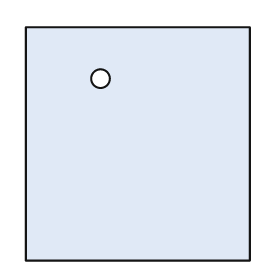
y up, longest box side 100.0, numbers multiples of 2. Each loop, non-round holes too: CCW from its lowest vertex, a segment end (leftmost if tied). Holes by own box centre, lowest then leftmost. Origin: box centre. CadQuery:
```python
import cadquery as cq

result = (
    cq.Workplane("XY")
    .moveTo(-48.0, -50.0)
    .lineTo(48.0, -50.0)
    .lineTo(48.0, 50.0)
    .lineTo(-48.0, 50.0)
    .close()
    .moveTo(-16.0, 28.0)
    .circle(4.0)
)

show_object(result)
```